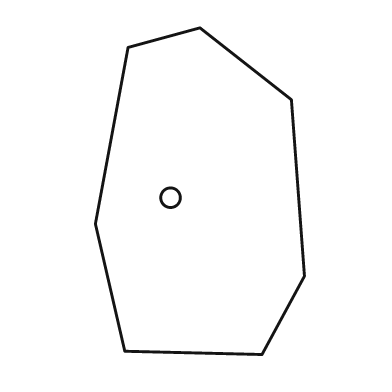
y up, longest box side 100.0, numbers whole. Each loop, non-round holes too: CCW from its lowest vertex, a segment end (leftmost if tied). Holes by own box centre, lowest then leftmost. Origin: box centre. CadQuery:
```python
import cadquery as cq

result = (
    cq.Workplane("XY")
    .moveTo(19.0, -50.0)
    .lineTo(32.0, -26.0)
    .lineTo(28.0, 28.0)
    .lineTo(0.0, 50.0)
    .lineTo(-22.0, 44.0)
    .lineTo(-32.0, -10.0)
    .lineTo(-23.0, -49.0)
    .close()
    .moveTo(-9.0, -2.0)
    .circle(3.0)
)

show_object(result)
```